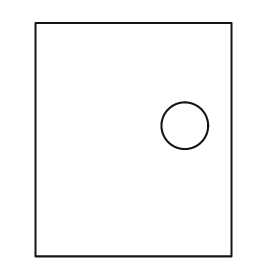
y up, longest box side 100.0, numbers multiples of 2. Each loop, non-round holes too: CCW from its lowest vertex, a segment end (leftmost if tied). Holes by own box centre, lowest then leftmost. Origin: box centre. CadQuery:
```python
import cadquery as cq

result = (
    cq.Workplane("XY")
    .moveTo(-42.0, -50.0)
    .lineTo(42.0, -50.0)
    .lineTo(42.0, 50.0)
    .lineTo(-42.0, 50.0)
    .close()
    .moveTo(22.0, 6.0)
    .circle(10.0)
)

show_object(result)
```